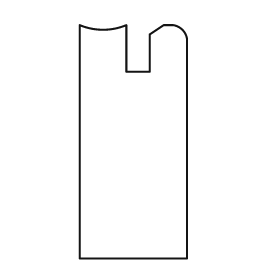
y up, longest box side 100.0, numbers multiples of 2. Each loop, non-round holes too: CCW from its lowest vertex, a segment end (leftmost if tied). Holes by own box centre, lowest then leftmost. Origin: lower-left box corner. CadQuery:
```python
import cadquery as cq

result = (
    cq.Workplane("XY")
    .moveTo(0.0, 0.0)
    .lineTo(46.0, 0.0)
    .lineTo(46.0, 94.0)
    .threePointArc((44.0, 98.0), (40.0, 100.0))
    .lineTo(36.0, 100.0)
    .lineTo(30.0, 96.0)
    .lineTo(30.0, 80.0)
    .lineTo(20.0, 80.0)
    .lineTo(20.0, 100.0)
    .threePointArc((10.0, 98.0), (0.0, 100.0))
    .close()
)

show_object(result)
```